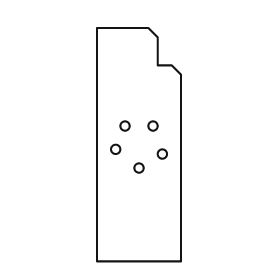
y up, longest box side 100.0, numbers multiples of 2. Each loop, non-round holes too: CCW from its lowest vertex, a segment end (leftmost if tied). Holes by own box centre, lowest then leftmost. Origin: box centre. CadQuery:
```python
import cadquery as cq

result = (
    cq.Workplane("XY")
    .moveTo(-18.0, -50.0)
    .lineTo(18.0, -50.0)
    .lineTo(18.0, 30.0)
    .lineTo(14.0, 34.0)
    .lineTo(8.0, 34.0)
    .lineTo(8.0, 46.0)
    .lineTo(4.0, 50.0)
    .lineTo(-18.0, 50.0)
    .close()
    .moveTo(0.0, -10.0)
    .circle(2.0)
    .moveTo(10.0, -4.0)
    .circle(2.0)
    .moveTo(-10.0, -2.0)
    .circle(2.0)
    .moveTo(-6.0, 8.0)
    .circle(2.0)
    .moveTo(6.0, 8.0)
    .circle(2.0)
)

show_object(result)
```